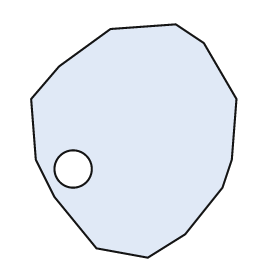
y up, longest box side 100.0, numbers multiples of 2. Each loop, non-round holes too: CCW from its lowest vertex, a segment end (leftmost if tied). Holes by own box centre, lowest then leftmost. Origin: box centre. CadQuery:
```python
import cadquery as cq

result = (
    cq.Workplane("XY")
    .moveTo(6.0, -50.0)
    .lineTo(22.0, -40.0)
    .lineTo(38.0, -20.0)
    .lineTo(42.0, -8.0)
    .lineTo(44.0, 18.0)
    .lineTo(30.0, 42.0)
    .lineTo(18.0, 50.0)
    .lineTo(-10.0, 48.0)
    .lineTo(-32.0, 32.0)
    .lineTo(-44.0, 18.0)
    .lineTo(-42.0, -8.0)
    .lineTo(-34.0, -24.0)
    .lineTo(-16.0, -46.0)
    .close()
    .moveTo(-26.0, -12.0)
    .circle(8.0)
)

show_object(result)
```